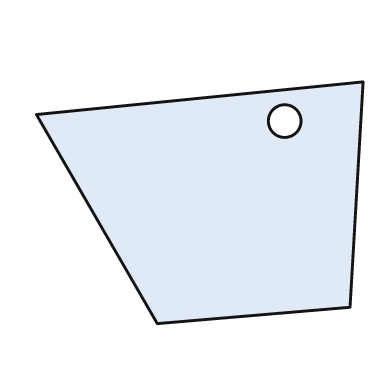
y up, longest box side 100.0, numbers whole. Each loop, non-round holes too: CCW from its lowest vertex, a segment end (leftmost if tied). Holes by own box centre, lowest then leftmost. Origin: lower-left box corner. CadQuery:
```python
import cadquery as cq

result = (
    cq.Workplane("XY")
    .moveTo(37.0, 0.0)
    .lineTo(96.0, 5.0)
    .lineTo(100.0, 74.0)
    .lineTo(0.0, 64.0)
    .close()
    .moveTo(76.0, 62.0)
    .circle(5.0)
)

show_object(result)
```